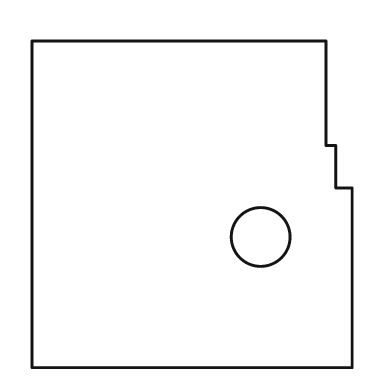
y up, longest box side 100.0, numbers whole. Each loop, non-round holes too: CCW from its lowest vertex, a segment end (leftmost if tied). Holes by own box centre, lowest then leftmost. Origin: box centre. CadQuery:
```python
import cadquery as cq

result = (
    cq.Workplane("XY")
    .moveTo(-49.0, -50.0)
    .lineTo(49.0, -50.0)
    .lineTo(49.0, 5.0)
    .lineTo(44.0, 5.0)
    .lineTo(44.0, 18.0)
    .lineTo(41.0, 18.0)
    .lineTo(41.0, 50.0)
    .lineTo(-49.0, 50.0)
    .close()
    .moveTo(21.0, -10.0)
    .circle(9.0)
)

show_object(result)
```